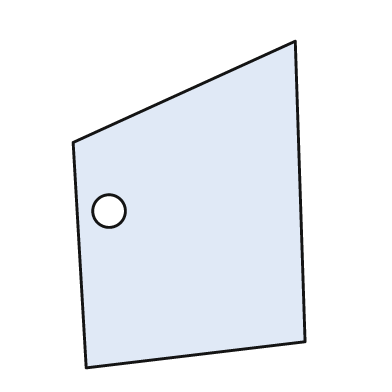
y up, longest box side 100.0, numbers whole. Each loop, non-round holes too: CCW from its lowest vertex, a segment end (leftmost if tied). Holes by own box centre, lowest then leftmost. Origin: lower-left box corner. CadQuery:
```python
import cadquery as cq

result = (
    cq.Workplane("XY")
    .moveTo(4.0, 0.0)
    .lineTo(71.0, 8.0)
    .lineTo(68.0, 100.0)
    .lineTo(0.0, 69.0)
    .close()
    .moveTo(11.0, 48.0)
    .circle(5.0)
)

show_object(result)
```